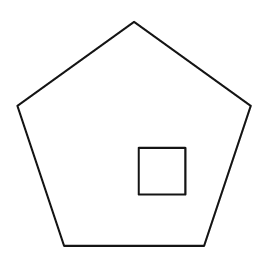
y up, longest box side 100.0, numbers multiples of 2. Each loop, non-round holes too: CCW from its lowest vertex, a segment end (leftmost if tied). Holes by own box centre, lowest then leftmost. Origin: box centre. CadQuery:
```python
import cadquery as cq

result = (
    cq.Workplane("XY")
    .moveTo(-30.0, -48.0)
    .lineTo(30.0, -48.0)
    .lineTo(50.0, 12.0)
    .lineTo(0.0, 48.0)
    .lineTo(-50.0, 12.0)
    .close()
    .moveTo(2.0, -26.0)
    .lineTo(22.0, -26.0)
    .lineTo(22.0, -6.0)
    .lineTo(2.0, -6.0)
    .close()
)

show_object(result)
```